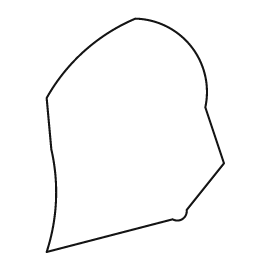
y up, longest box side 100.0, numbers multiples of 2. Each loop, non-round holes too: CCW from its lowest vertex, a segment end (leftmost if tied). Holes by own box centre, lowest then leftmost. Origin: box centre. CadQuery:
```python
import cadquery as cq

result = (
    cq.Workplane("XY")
    .moveTo(-38.0, -50.0)
    .lineTo(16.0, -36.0)
    .threePointArc((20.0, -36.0), (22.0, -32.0))
    .lineTo(38.0, -12.0)
    .lineTo(30.0, 12.0)
    .threePointArc((24.0, 38.0), (0.0, 50.0))
    .threePointArc((-22.0, 36.0), (-38.0, 16.0))
    .lineTo(-36.0, -6.0)
    .threePointArc((-34.0, -28.0), (-38.0, -50.0))
    .close()
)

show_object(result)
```